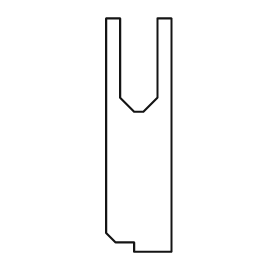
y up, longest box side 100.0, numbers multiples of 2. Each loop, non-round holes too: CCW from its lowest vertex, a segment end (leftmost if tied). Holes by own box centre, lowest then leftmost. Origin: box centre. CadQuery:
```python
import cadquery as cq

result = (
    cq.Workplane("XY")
    .moveTo(-2.0, -50.0)
    .lineTo(14.0, -50.0)
    .lineTo(14.0, 50.0)
    .lineTo(8.0, 50.0)
    .lineTo(8.0, 16.0)
    .lineTo(2.0, 10.0)
    .lineTo(-2.0, 10.0)
    .lineTo(-8.0, 16.0)
    .lineTo(-8.0, 50.0)
    .lineTo(-14.0, 50.0)
    .lineTo(-14.0, -42.0)
    .lineTo(-10.0, -46.0)
    .lineTo(-2.0, -46.0)
    .close()
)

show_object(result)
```